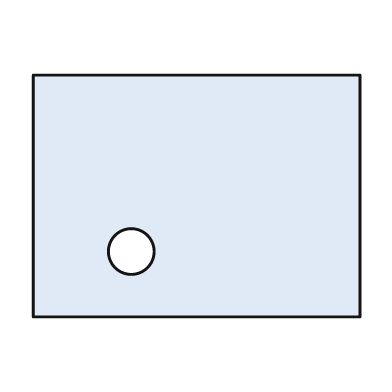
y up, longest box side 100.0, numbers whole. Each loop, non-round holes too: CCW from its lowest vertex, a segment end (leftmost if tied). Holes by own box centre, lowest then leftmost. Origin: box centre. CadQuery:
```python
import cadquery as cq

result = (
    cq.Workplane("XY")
    .moveTo(-50.0, -37.0)
    .lineTo(50.0, -37.0)
    .lineTo(50.0, 37.0)
    .lineTo(-50.0, 37.0)
    .close()
    .moveTo(-20.0, -17.0)
    .circle(7.0)
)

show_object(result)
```